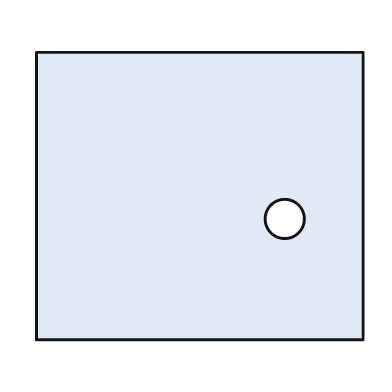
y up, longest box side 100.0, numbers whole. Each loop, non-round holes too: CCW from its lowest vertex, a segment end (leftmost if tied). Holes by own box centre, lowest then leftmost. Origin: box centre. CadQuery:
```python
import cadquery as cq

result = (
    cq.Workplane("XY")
    .moveTo(-50.0, -44.0)
    .lineTo(50.0, -44.0)
    .lineTo(50.0, 44.0)
    .lineTo(-50.0, 44.0)
    .close()
    .moveTo(26.0, -7.0)
    .circle(6.0)
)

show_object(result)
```